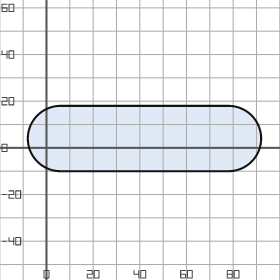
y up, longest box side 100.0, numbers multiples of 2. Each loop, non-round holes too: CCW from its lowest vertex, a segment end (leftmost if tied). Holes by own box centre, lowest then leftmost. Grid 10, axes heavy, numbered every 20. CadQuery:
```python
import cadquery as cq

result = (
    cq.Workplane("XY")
    .moveTo(6.0, -10.0)
    .lineTo(78.0, -10.0)
    .threePointArc((92.0, 4.0), (78.0, 18.0))
    .lineTo(6.0, 18.0)
    .threePointArc((-8.0, 4.0), (6.0, -10.0))
    .close()
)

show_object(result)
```